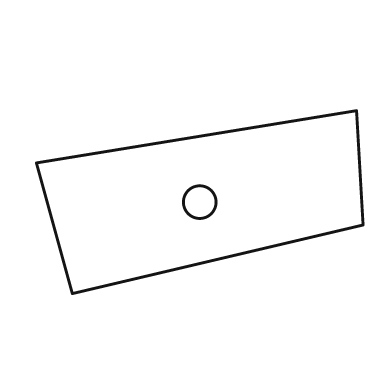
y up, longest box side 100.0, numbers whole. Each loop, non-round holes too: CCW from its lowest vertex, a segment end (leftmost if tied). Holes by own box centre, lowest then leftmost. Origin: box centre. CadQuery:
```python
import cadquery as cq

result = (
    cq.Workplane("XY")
    .moveTo(-39.0, -28.0)
    .lineTo(50.0, -7.0)
    .lineTo(48.0, 28.0)
    .lineTo(-50.0, 12.0)
    .close()
    .moveTo(0.0, 0.0)
    .circle(5.0)
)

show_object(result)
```